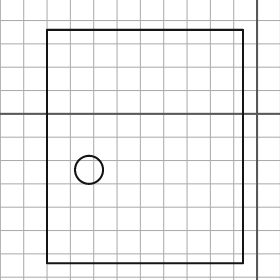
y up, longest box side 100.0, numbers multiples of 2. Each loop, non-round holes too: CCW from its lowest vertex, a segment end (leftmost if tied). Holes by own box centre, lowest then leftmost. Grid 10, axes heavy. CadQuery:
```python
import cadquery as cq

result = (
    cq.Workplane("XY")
    .moveTo(-90.0, -64.0)
    .lineTo(-6.0, -64.0)
    .lineTo(-6.0, 36.0)
    .lineTo(-90.0, 36.0)
    .close()
    .moveTo(-72.0, -24.0)
    .circle(6.0)
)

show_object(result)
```